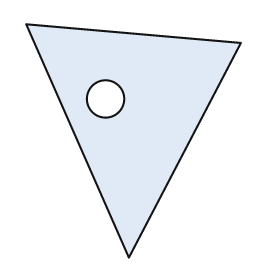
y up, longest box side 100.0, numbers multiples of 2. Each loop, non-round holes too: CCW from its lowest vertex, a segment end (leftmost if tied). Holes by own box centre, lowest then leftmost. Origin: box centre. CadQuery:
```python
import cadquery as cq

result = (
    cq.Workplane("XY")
    .moveTo(-2.0, -50.0)
    .lineTo(46.0, 42.0)
    .lineTo(-46.0, 50.0)
    .close()
    .moveTo(-12.0, 18.0)
    .circle(8.0)
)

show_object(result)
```